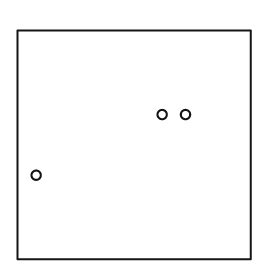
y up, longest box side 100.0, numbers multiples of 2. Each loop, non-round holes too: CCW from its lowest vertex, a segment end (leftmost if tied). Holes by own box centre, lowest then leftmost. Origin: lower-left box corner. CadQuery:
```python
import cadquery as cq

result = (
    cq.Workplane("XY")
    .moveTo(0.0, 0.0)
    .lineTo(100.0, 0.0)
    .lineTo(100.0, 98.0)
    .lineTo(0.0, 98.0)
    .close()
    .moveTo(8.0, 36.0)
    .circle(2.0)
    .moveTo(62.0, 62.0)
    .circle(2.0)
    .moveTo(72.0, 62.0)
    .circle(2.0)
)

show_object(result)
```